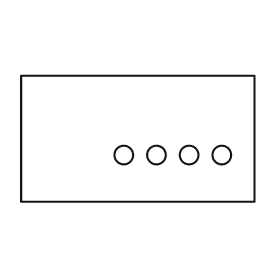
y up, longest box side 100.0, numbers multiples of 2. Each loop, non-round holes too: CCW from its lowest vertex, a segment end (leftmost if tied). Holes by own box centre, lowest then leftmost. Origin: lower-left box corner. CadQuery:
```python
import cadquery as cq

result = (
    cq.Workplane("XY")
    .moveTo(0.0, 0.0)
    .lineTo(100.0, 0.0)
    .lineTo(100.0, 54.0)
    .lineTo(0.0, 54.0)
    .close()
    .moveTo(44.0, 20.0)
    .circle(4.0)
    .moveTo(58.0, 20.0)
    .circle(4.0)
    .moveTo(72.0, 20.0)
    .circle(4.0)
    .moveTo(86.0, 20.0)
    .circle(4.0)
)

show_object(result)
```